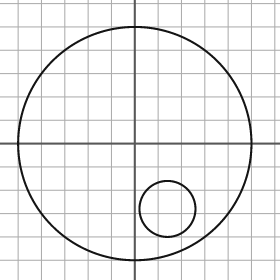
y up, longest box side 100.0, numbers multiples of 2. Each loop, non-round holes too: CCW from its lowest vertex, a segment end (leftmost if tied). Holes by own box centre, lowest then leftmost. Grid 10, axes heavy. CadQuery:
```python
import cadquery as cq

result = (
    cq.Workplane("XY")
    .moveTo(0.0, 0.0)
    .circle(50.0)
    .moveTo(14.0, -28.0)
    .circle(12.0)
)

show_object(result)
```